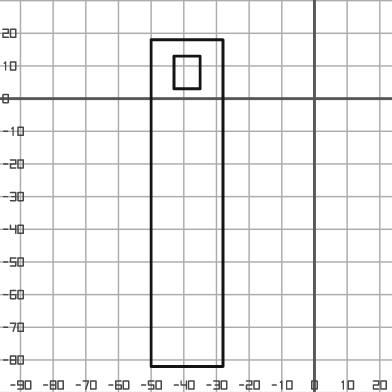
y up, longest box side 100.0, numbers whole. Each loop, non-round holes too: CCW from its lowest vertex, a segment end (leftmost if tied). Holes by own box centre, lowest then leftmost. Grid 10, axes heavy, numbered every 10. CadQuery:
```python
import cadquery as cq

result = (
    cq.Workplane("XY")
    .moveTo(-50.0, -82.0)
    .lineTo(-28.0, -82.0)
    .lineTo(-28.0, 18.0)
    .lineTo(-50.0, 18.0)
    .close()
    .moveTo(-43.0, 3.0)
    .lineTo(-35.0, 3.0)
    .lineTo(-35.0, 13.0)
    .lineTo(-43.0, 13.0)
    .close()
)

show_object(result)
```